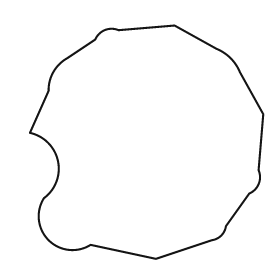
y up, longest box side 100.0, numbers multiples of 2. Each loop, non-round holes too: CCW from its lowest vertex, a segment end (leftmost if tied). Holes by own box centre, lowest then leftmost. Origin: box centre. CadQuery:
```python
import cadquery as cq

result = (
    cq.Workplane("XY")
    .moveTo(4.0, -50.0)
    .lineTo(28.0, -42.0)
    .threePointArc((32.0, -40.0), (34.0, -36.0))
    .lineTo(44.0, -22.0)
    .threePointArc((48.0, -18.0), (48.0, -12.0))
    .lineTo(50.0, 12.0)
    .lineTo(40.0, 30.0)
    .threePointArc((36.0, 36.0), (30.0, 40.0))
    .lineTo(12.0, 50.0)
    .lineTo(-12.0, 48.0)
    .threePointArc((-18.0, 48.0), (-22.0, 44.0))
    .lineTo(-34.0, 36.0)
    .threePointArc((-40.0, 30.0), (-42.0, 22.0))
    .lineTo(-50.0, 4.0)
    .threePointArc((-38.0, -8.0), (-44.0, -24.0))
    .threePointArc((-42.0, -42.0), (-24.0, -44.0))
    .close()
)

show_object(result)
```